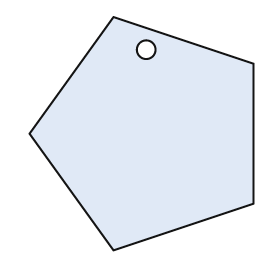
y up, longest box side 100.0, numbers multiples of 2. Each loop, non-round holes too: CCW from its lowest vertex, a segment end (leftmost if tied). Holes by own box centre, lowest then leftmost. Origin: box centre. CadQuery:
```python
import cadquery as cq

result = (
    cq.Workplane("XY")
    .moveTo(-12.0, -50.0)
    .lineTo(48.0, -30.0)
    .lineTo(48.0, 30.0)
    .lineTo(-12.0, 50.0)
    .lineTo(-48.0, 0.0)
    .close()
    .moveTo(2.0, 36.0)
    .circle(4.0)
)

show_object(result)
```